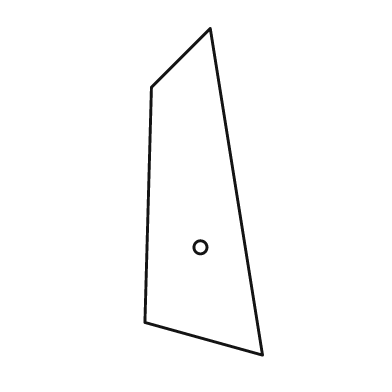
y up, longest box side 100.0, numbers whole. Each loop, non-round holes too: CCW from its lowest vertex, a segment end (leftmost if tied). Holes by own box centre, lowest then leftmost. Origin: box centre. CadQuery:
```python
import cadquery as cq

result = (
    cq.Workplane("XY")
    .moveTo(18.0, -50.0)
    .lineTo(2.0, 50.0)
    .lineTo(-16.0, 32.0)
    .lineTo(-18.0, -40.0)
    .close()
    .moveTo(-1.0, -17.0)
    .circle(2.0)
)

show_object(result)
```